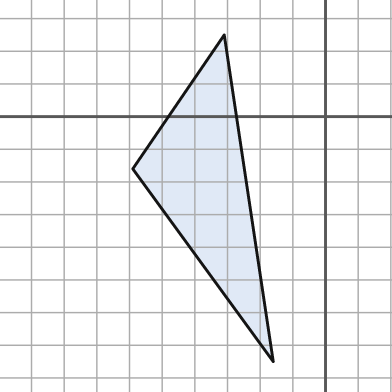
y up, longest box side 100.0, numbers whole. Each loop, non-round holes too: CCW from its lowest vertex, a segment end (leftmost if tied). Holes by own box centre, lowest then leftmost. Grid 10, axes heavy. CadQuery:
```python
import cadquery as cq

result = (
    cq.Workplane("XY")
    .moveTo(-16.0, -75.0)
    .lineTo(-31.0, 25.0)
    .lineTo(-59.0, -16.0)
    .close()
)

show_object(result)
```